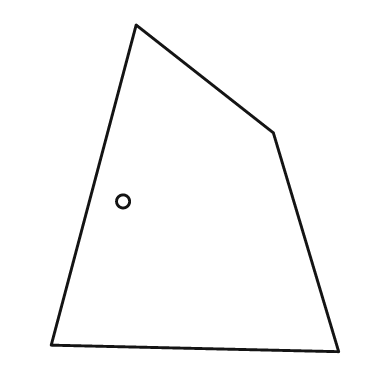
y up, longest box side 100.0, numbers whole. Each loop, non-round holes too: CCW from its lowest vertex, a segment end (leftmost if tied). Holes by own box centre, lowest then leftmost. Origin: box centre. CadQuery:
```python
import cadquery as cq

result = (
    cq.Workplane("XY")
    .moveTo(44.0, -50.0)
    .lineTo(24.0, 17.0)
    .lineTo(-18.0, 50.0)
    .lineTo(-44.0, -48.0)
    .close()
    .moveTo(-22.0, -4.0)
    .circle(2.0)
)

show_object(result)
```